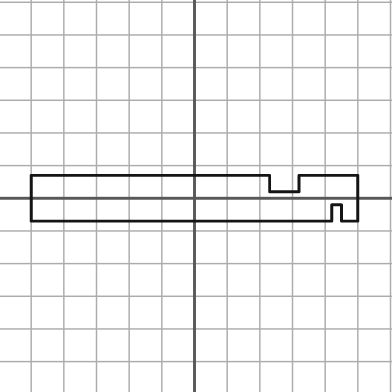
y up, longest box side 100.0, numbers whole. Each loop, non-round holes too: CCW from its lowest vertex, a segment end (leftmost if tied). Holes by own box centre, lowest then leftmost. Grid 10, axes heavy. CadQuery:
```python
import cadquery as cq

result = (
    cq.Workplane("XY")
    .moveTo(-50.0, -7.0)
    .lineTo(42.0, -7.0)
    .lineTo(42.0, -2.0)
    .lineTo(45.0, -2.0)
    .lineTo(45.0, -7.0)
    .lineTo(50.0, -7.0)
    .lineTo(50.0, 7.0)
    .lineTo(32.0, 7.0)
    .lineTo(32.0, 2.0)
    .lineTo(23.0, 2.0)
    .lineTo(23.0, 7.0)
    .lineTo(-50.0, 7.0)
    .close()
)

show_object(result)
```